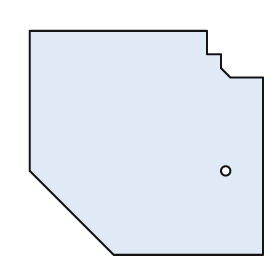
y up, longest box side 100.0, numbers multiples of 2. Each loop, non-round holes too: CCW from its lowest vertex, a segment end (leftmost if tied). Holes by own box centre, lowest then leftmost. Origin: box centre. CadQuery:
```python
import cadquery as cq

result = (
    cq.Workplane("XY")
    .moveTo(-14.0, -48.0)
    .lineTo(50.0, -48.0)
    .lineTo(50.0, 28.0)
    .lineTo(36.0, 28.0)
    .lineTo(32.0, 32.0)
    .lineTo(32.0, 38.0)
    .lineTo(26.0, 38.0)
    .lineTo(26.0, 48.0)
    .lineTo(-50.0, 48.0)
    .lineTo(-50.0, -12.0)
    .close()
    .moveTo(34.0, -12.0)
    .circle(2.0)
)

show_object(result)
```